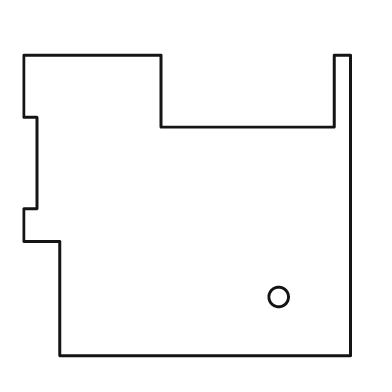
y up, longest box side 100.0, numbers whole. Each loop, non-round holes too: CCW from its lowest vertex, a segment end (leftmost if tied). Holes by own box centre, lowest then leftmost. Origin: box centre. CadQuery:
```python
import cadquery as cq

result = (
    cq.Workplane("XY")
    .moveTo(-39.0, -46.0)
    .lineTo(50.0, -46.0)
    .lineTo(50.0, 46.0)
    .lineTo(45.0, 46.0)
    .lineTo(45.0, 24.0)
    .lineTo(-8.0, 24.0)
    .lineTo(-8.0, 46.0)
    .lineTo(-50.0, 46.0)
    .lineTo(-50.0, 27.0)
    .lineTo(-46.0, 27.0)
    .lineTo(-46.0, -1.0)
    .lineTo(-50.0, -1.0)
    .lineTo(-50.0, -11.0)
    .lineTo(-39.0, -11.0)
    .close()
    .moveTo(28.0, -28.0)
    .circle(3.0)
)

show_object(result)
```